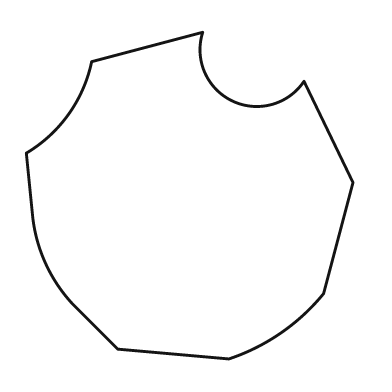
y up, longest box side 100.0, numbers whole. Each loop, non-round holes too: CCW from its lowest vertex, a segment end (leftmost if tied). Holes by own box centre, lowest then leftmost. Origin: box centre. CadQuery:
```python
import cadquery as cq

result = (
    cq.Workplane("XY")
    .moveTo(12.0, -50.0)
    .threePointArc((28.0, -42.0), (41.0, -30.0))
    .lineTo(50.0, 4.0)
    .lineTo(35.0, 35.0)
    .threePointArc((13.0, 29.0), (4.0, 50.0))
    .lineTo(-30.0, 41.0)
    .threePointArc((-37.0, 25.0), (-50.0, 13.0))
    .lineTo(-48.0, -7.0)
    .threePointArc((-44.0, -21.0), (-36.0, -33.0))
    .lineTo(-22.0, -47.0)
    .close()
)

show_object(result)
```